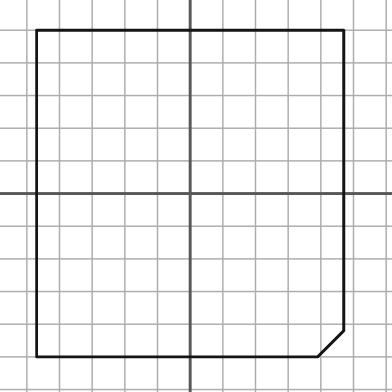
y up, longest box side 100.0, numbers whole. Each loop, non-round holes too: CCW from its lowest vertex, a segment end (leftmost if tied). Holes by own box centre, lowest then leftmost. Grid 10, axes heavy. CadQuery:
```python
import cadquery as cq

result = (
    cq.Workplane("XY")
    .moveTo(-47.0, -50.0)
    .lineTo(39.0, -50.0)
    .lineTo(47.0, -42.0)
    .lineTo(47.0, 50.0)
    .lineTo(-47.0, 50.0)
    .close()
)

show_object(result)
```